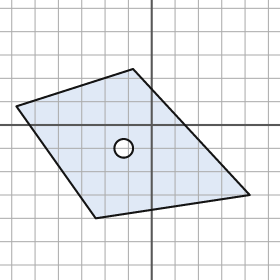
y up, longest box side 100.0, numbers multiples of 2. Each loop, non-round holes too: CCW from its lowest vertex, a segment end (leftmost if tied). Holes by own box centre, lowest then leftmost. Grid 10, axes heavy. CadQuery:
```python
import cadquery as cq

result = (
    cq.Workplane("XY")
    .moveTo(-24.0, -40.0)
    .lineTo(42.0, -30.0)
    .lineTo(-8.0, 24.0)
    .lineTo(-58.0, 8.0)
    .close()
    .moveTo(-12.0, -10.0)
    .circle(4.0)
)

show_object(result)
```